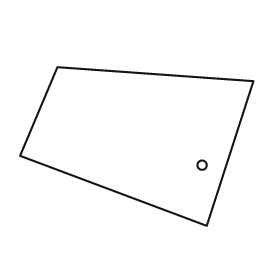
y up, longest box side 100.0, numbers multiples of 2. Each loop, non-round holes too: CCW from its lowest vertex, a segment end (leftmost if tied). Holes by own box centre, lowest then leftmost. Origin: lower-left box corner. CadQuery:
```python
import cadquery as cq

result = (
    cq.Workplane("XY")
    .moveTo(80.0, 0.0)
    .lineTo(100.0, 62.0)
    .lineTo(16.0, 68.0)
    .lineTo(0.0, 30.0)
    .close()
    .moveTo(78.0, 26.0)
    .circle(2.0)
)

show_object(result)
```